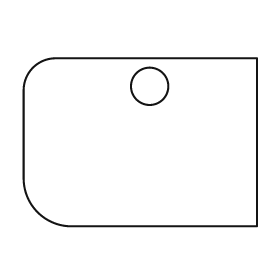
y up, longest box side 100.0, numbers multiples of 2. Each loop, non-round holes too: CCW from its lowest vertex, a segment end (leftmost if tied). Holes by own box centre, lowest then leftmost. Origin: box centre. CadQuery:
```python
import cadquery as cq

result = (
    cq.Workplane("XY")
    .moveTo(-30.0, -36.0)
    .lineTo(50.0, -36.0)
    .lineTo(50.0, 36.0)
    .lineTo(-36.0, 36.0)
    .threePointArc((-46.0, 32.0), (-50.0, 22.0))
    .lineTo(-50.0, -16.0)
    .threePointArc((-44.0, -30.0), (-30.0, -36.0))
    .close()
    .moveTo(4.0, 24.0)
    .circle(8.0)
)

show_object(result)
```